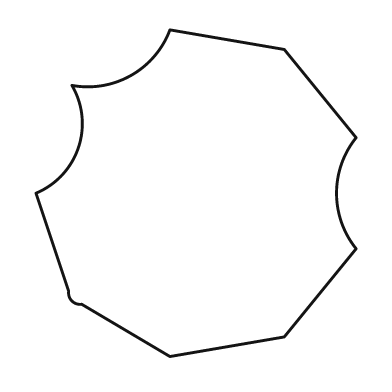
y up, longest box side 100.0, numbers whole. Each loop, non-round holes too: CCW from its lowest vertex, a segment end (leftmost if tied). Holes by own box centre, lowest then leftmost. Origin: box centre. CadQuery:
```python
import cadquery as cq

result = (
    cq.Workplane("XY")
    .moveTo(-8.0, -50.0)
    .lineTo(27.0, -44.0)
    .lineTo(49.0, -17.0)
    .threePointArc((43.0, 0.0), (49.0, 17.0))
    .lineTo(27.0, 44.0)
    .lineTo(-8.0, 50.0)
    .threePointArc((-20.0, 36.0), (-38.0, 33.0))
    .threePointArc((-36.0, 14.0), (-49.0, 0.0))
    .lineTo(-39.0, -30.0)
    .threePointArc((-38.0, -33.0), (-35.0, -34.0))
    .close()
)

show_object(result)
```